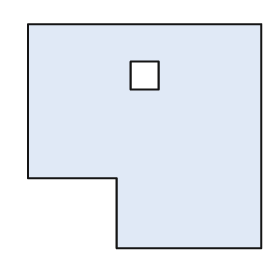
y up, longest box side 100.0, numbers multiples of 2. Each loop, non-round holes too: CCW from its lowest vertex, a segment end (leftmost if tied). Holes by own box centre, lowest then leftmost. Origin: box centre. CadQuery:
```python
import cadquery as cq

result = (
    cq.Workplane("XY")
    .moveTo(-12.0, -48.0)
    .lineTo(50.0, -48.0)
    .lineTo(50.0, 48.0)
    .lineTo(-50.0, 48.0)
    .lineTo(-50.0, -18.0)
    .lineTo(-12.0, -18.0)
    .close()
    .moveTo(-6.0, 20.0)
    .lineTo(6.0, 20.0)
    .lineTo(6.0, 32.0)
    .lineTo(-6.0, 32.0)
    .close()
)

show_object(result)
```